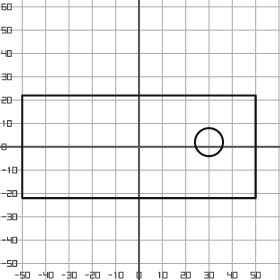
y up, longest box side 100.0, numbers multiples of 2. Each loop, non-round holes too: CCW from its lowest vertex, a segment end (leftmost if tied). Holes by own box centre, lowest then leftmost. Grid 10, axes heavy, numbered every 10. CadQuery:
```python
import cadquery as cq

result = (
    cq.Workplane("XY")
    .moveTo(-50.0, -22.0)
    .lineTo(50.0, -22.0)
    .lineTo(50.0, 22.0)
    .lineTo(-50.0, 22.0)
    .close()
    .moveTo(30.0, 2.0)
    .circle(6.0)
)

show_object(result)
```